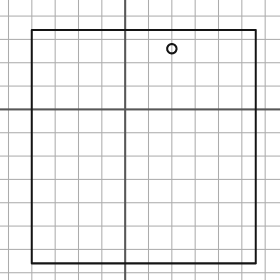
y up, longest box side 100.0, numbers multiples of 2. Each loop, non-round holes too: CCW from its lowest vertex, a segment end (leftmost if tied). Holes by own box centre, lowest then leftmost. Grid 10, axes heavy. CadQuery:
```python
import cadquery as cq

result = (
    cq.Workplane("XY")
    .moveTo(-40.0, -66.0)
    .lineTo(56.0, -66.0)
    .lineTo(56.0, 34.0)
    .lineTo(-40.0, 34.0)
    .close()
    .moveTo(20.0, 26.0)
    .circle(2.0)
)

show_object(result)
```